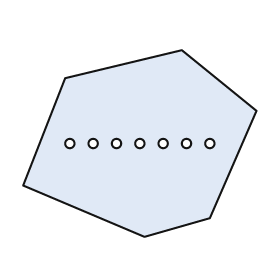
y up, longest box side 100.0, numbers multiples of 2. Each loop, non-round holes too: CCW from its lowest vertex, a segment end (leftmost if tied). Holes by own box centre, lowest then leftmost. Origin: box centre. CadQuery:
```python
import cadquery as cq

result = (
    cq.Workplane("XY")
    .moveTo(2.0, -40.0)
    .lineTo(30.0, -32.0)
    .lineTo(50.0, 14.0)
    .lineTo(18.0, 40.0)
    .lineTo(-32.0, 28.0)
    .lineTo(-50.0, -18.0)
    .close()
    .moveTo(-30.0, 0.0)
    .circle(2.0)
    .moveTo(-20.0, 0.0)
    .circle(2.0)
    .moveTo(-10.0, 0.0)
    .circle(2.0)
    .moveTo(0.0, 0.0)
    .circle(2.0)
    .moveTo(10.0, 0.0)
    .circle(2.0)
    .moveTo(20.0, 0.0)
    .circle(2.0)
    .moveTo(30.0, 0.0)
    .circle(2.0)
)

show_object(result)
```